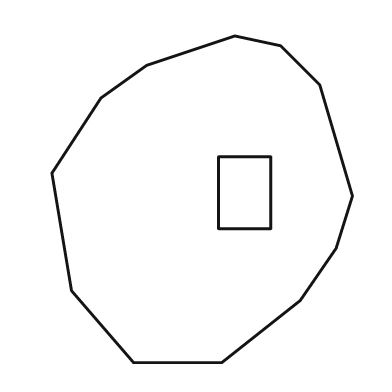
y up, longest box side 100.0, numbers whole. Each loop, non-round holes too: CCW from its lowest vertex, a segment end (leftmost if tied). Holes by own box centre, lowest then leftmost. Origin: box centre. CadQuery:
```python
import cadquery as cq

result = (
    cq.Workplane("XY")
    .moveTo(-21.0, -50.0)
    .lineTo(6.0, -50.0)
    .lineTo(30.0, -31.0)
    .lineTo(41.0, -15.0)
    .lineTo(46.0, 1.0)
    .lineTo(36.0, 35.0)
    .lineTo(24.0, 47.0)
    .lineTo(10.0, 50.0)
    .lineTo(-17.0, 41.0)
    .lineTo(-31.0, 31.0)
    .lineTo(-46.0, 8.0)
    .lineTo(-40.0, -28.0)
    .close()
    .moveTo(5.0, -9.0)
    .lineTo(21.0, -9.0)
    .lineTo(21.0, 13.0)
    .lineTo(5.0, 13.0)
    .close()
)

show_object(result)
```